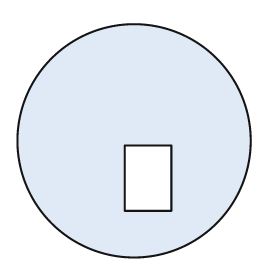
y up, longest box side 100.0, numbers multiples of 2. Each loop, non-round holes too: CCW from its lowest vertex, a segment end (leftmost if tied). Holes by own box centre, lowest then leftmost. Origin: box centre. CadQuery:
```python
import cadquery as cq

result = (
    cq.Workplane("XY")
    .moveTo(0.0, 0.0)
    .circle(50.0)
    .moveTo(-4.0, -30.0)
    .lineTo(16.0, -30.0)
    .lineTo(16.0, -2.0)
    .lineTo(-4.0, -2.0)
    .close()
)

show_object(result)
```